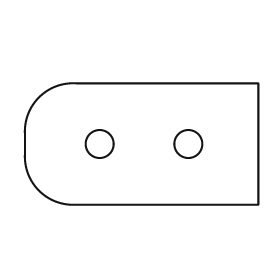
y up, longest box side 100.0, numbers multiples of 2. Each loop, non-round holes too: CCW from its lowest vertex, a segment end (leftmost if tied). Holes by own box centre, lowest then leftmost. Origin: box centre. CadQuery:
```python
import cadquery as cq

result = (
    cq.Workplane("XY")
    .moveTo(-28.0, -26.0)
    .lineTo(50.0, -26.0)
    .lineTo(50.0, 26.0)
    .lineTo(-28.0, 26.0)
    .threePointArc((-44.0, 20.0), (-50.0, 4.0))
    .lineTo(-50.0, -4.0)
    .threePointArc((-44.0, -20.0), (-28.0, -26.0))
    .close()
    .moveTo(-18.0, 0.0)
    .circle(6.0)
    .moveTo(20.0, 0.0)
    .circle(6.0)
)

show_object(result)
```